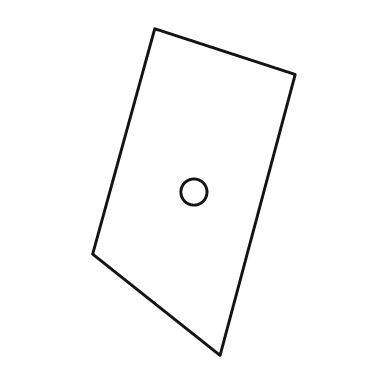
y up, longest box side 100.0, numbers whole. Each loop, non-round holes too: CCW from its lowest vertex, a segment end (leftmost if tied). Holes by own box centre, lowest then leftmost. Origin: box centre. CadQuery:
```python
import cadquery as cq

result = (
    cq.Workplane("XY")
    .moveTo(8.0, -50.0)
    .lineTo(31.0, 36.0)
    .lineTo(-12.0, 50.0)
    .lineTo(-31.0, -19.0)
    .close()
    .moveTo(0.0, 0.0)
    .circle(4.0)
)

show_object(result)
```